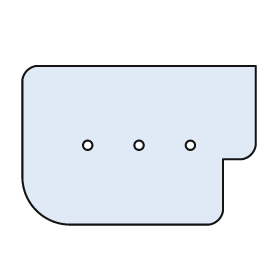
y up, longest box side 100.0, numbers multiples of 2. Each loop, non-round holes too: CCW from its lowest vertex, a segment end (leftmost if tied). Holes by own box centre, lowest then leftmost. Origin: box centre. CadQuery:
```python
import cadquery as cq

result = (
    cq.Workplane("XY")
    .moveTo(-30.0, -34.0)
    .lineTo(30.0, -34.0)
    .threePointArc((34.0, -32.0), (36.0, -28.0))
    .lineTo(36.0, -6.0)
    .lineTo(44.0, -6.0)
    .threePointArc((48.0, -4.0), (50.0, 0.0))
    .lineTo(50.0, 34.0)
    .lineTo(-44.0, 34.0)
    .threePointArc((-48.0, 32.0), (-50.0, 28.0))
    .lineTo(-50.0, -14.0)
    .threePointArc((-44.0, -28.0), (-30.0, -34.0))
    .close()
    .moveTo(-22.0, 0.0)
    .circle(2.0)
    .moveTo(0.0, 0.0)
    .circle(2.0)
    .moveTo(22.0, 0.0)
    .circle(2.0)
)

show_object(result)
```